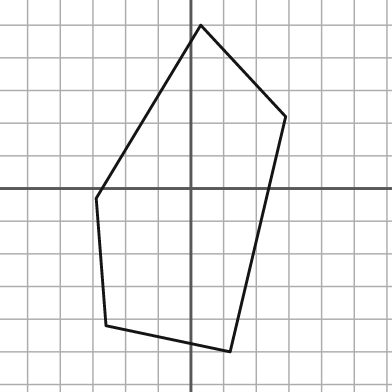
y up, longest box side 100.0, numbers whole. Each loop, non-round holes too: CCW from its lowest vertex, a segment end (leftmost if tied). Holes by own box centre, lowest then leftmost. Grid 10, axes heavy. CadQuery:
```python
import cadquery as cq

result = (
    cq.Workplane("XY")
    .moveTo(12.0, -50.0)
    .lineTo(29.0, 22.0)
    .lineTo(3.0, 50.0)
    .lineTo(-29.0, -3.0)
    .lineTo(-26.0, -42.0)
    .close()
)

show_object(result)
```